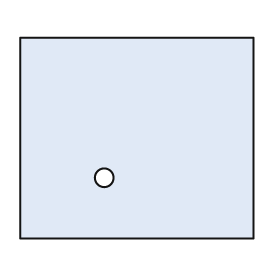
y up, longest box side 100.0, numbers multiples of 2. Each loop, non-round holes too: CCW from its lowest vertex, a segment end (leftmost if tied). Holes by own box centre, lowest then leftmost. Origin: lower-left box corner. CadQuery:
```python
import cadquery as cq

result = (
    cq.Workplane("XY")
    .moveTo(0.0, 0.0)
    .lineTo(100.0, 0.0)
    .lineTo(100.0, 86.0)
    .lineTo(0.0, 86.0)
    .close()
    .moveTo(36.0, 26.0)
    .circle(4.0)
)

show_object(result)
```